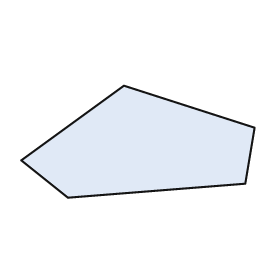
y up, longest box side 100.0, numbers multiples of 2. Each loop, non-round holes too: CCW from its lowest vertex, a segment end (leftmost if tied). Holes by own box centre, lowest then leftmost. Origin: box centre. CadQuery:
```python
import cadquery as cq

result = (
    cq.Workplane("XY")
    .moveTo(-30.0, -24.0)
    .lineTo(46.0, -18.0)
    .lineTo(50.0, 6.0)
    .lineTo(-6.0, 24.0)
    .lineTo(-50.0, -8.0)
    .close()
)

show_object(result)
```